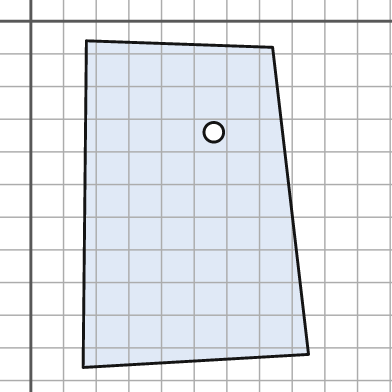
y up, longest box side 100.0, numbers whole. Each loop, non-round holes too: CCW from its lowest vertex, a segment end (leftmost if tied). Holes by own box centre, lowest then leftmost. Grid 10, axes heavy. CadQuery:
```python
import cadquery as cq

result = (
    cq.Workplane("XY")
    .moveTo(16.0, -106.0)
    .lineTo(85.0, -102.0)
    .lineTo(74.0, -8.0)
    .lineTo(17.0, -6.0)
    .close()
    .moveTo(56.0, -34.0)
    .circle(3.0)
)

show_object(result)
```